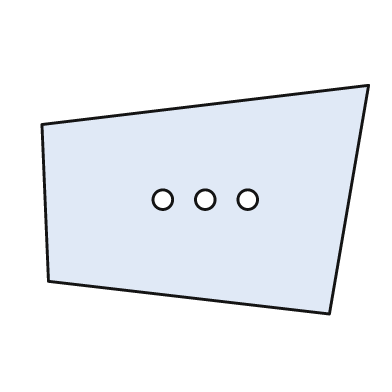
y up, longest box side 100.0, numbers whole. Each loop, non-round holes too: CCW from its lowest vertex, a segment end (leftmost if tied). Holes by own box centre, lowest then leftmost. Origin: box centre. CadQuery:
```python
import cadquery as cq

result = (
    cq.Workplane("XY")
    .moveTo(38.0, -35.0)
    .lineTo(50.0, 35.0)
    .lineTo(-50.0, 23.0)
    .lineTo(-48.0, -25.0)
    .close()
    .moveTo(-13.0, 0.0)
    .circle(3.0)
    .moveTo(0.0, 0.0)
    .circle(3.0)
    .moveTo(13.0, 0.0)
    .circle(3.0)
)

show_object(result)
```